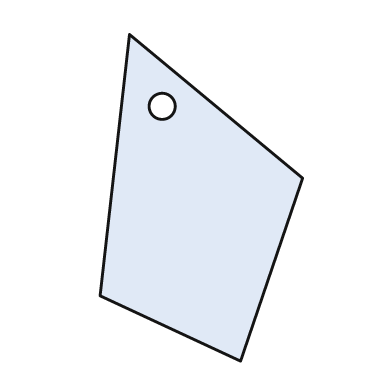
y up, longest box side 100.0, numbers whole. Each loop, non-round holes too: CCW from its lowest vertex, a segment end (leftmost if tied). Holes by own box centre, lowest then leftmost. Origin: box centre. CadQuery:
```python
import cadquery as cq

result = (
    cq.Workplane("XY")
    .moveTo(12.0, -50.0)
    .lineTo(31.0, 6.0)
    .lineTo(-22.0, 50.0)
    .lineTo(-31.0, -30.0)
    .close()
    .moveTo(-12.0, 28.0)
    .circle(4.0)
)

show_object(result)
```